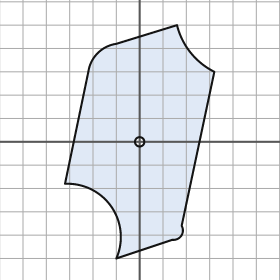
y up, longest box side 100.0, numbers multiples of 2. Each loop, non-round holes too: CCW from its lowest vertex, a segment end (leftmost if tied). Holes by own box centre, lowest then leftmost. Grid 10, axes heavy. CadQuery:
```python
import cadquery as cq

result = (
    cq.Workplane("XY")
    .moveTo(-10.0, -50.0)
    .lineTo(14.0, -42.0)
    .threePointArc((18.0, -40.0), (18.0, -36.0))
    .lineTo(32.0, 30.0)
    .threePointArc((22.0, 38.0), (16.0, 50.0))
    .lineTo(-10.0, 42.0)
    .threePointArc((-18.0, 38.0), (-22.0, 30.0))
    .lineTo(-32.0, -18.0)
    .threePointArc((-12.0, -28.0), (-10.0, -50.0))
    .close()
    .moveTo(0.0, 0.0)
    .circle(2.0)
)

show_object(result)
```